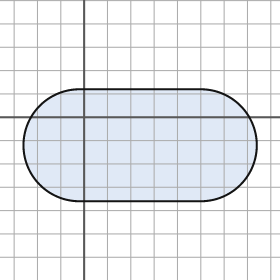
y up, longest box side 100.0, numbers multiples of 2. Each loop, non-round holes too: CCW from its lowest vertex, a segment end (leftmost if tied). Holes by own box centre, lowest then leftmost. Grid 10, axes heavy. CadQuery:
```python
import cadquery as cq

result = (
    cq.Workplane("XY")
    .moveTo(-2.0, -36.0)
    .lineTo(50.0, -36.0)
    .threePointArc((74.0, -12.0), (50.0, 12.0))
    .lineTo(-2.0, 12.0)
    .threePointArc((-26.0, -12.0), (-2.0, -36.0))
    .close()
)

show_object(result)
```